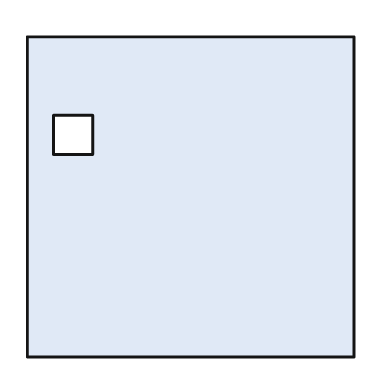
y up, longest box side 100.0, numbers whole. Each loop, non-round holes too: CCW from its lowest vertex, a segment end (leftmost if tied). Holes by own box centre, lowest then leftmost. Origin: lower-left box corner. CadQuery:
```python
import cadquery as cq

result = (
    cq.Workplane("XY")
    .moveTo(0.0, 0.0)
    .lineTo(100.0, 0.0)
    .lineTo(100.0, 98.0)
    .lineTo(0.0, 98.0)
    .close()
    .moveTo(8.0, 62.0)
    .lineTo(20.0, 62.0)
    .lineTo(20.0, 74.0)
    .lineTo(8.0, 74.0)
    .close()
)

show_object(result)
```